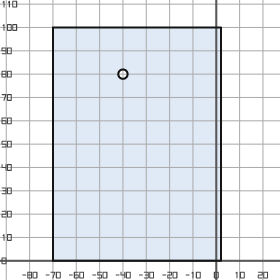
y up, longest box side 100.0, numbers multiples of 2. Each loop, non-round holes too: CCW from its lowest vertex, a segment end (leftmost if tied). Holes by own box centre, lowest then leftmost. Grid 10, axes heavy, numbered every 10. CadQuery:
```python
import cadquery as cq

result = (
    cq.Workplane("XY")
    .moveTo(-70.0, 0.0)
    .lineTo(2.0, 0.0)
    .lineTo(2.0, 100.0)
    .lineTo(-70.0, 100.0)
    .close()
    .moveTo(-40.0, 80.0)
    .circle(2.0)
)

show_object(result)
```